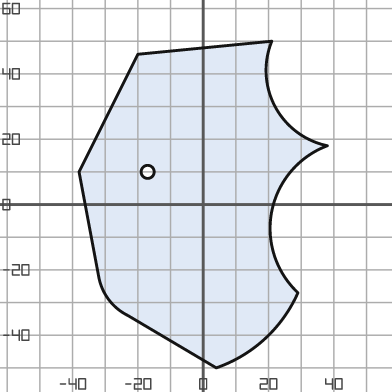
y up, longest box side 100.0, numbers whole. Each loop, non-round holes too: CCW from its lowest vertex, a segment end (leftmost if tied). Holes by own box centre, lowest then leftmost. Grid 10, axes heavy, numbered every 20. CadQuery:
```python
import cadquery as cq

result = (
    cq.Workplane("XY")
    .moveTo(4.0, -50.0)
    .threePointArc((19.0, -41.0), (29.0, -27.0))
    .threePointArc((21.0, -2.0), (38.0, 18.0))
    .threePointArc((22.0, 30.0), (21.0, 50.0))
    .lineTo(-20.0, 46.0)
    .lineTo(-38.0, 10.0)
    .lineTo(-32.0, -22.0)
    .threePointArc((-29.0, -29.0), (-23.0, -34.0))
    .close()
    .moveTo(-17.0, 10.0)
    .circle(2.0)
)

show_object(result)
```